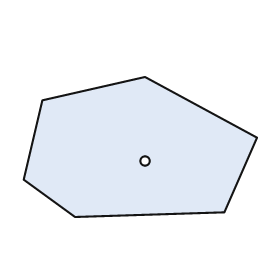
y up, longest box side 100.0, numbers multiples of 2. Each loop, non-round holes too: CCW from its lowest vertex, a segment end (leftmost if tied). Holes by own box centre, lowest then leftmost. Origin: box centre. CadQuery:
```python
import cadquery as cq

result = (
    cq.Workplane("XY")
    .moveTo(-28.0, -30.0)
    .lineTo(36.0, -28.0)
    .lineTo(50.0, 4.0)
    .lineTo(2.0, 30.0)
    .lineTo(-42.0, 20.0)
    .lineTo(-50.0, -14.0)
    .close()
    .moveTo(2.0, -6.0)
    .circle(2.0)
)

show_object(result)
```